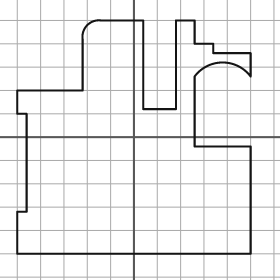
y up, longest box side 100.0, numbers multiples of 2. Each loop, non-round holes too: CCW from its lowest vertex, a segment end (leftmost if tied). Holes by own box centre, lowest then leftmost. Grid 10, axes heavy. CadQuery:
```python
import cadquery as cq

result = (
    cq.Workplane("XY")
    .moveTo(-50.0, -50.0)
    .lineTo(50.0, -50.0)
    .lineTo(50.0, -4.0)
    .lineTo(26.0, -4.0)
    .lineTo(26.0, 26.0)
    .threePointArc((38.0, 32.0), (50.0, 26.0))
    .lineTo(50.0, 36.0)
    .lineTo(34.0, 36.0)
    .lineTo(34.0, 40.0)
    .lineTo(26.0, 40.0)
    .lineTo(26.0, 50.0)
    .lineTo(18.0, 50.0)
    .lineTo(18.0, 12.0)
    .lineTo(4.0, 12.0)
    .lineTo(4.0, 50.0)
    .lineTo(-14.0, 50.0)
    .threePointArc((-20.0, 48.0), (-22.0, 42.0))
    .lineTo(-22.0, 20.0)
    .lineTo(-50.0, 20.0)
    .lineTo(-50.0, 10.0)
    .lineTo(-46.0, 10.0)
    .lineTo(-46.0, -32.0)
    .lineTo(-50.0, -32.0)
    .close()
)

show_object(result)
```